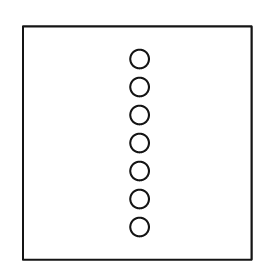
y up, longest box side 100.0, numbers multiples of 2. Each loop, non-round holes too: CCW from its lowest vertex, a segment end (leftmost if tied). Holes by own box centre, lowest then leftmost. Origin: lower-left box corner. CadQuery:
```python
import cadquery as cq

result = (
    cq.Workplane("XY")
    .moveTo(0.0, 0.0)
    .lineTo(98.0, 0.0)
    .lineTo(98.0, 100.0)
    .lineTo(0.0, 100.0)
    .close()
    .moveTo(50.0, 14.0)
    .circle(4.0)
    .moveTo(50.0, 26.0)
    .circle(4.0)
    .moveTo(50.0, 38.0)
    .circle(4.0)
    .moveTo(50.0, 50.0)
    .circle(4.0)
    .moveTo(50.0, 62.0)
    .circle(4.0)
    .moveTo(50.0, 74.0)
    .circle(4.0)
    .moveTo(50.0, 86.0)
    .circle(4.0)
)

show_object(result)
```